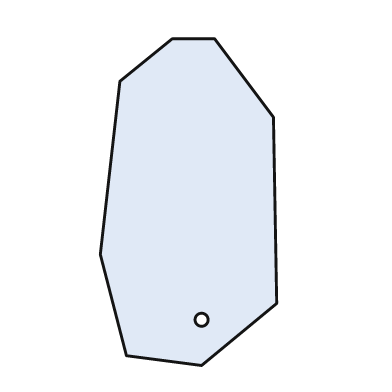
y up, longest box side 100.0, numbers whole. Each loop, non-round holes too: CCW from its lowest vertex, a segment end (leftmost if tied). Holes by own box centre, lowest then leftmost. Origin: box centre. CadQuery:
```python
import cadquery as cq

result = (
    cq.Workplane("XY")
    .moveTo(4.0, -50.0)
    .lineTo(27.0, -31.0)
    .lineTo(26.0, 26.0)
    .lineTo(8.0, 50.0)
    .lineTo(-5.0, 50.0)
    .lineTo(-21.0, 37.0)
    .lineTo(-27.0, -16.0)
    .lineTo(-19.0, -47.0)
    .close()
    .moveTo(4.0, -36.0)
    .circle(2.0)
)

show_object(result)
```